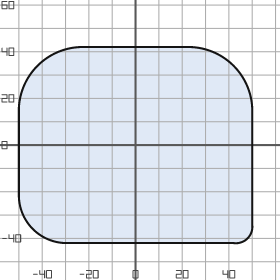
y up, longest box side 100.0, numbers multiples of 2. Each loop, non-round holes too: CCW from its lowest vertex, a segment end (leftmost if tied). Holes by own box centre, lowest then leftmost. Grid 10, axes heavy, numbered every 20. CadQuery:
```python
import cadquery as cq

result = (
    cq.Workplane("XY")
    .moveTo(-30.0, -42.0)
    .lineTo(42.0, -42.0)
    .threePointArc((48.0, -40.0), (50.0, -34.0))
    .lineTo(50.0, 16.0)
    .threePointArc((42.0, 34.0), (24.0, 42.0))
    .lineTo(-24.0, 42.0)
    .threePointArc((-42.0, 34.0), (-50.0, 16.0))
    .lineTo(-50.0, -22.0)
    .threePointArc((-44.0, -36.0), (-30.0, -42.0))
    .close()
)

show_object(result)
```